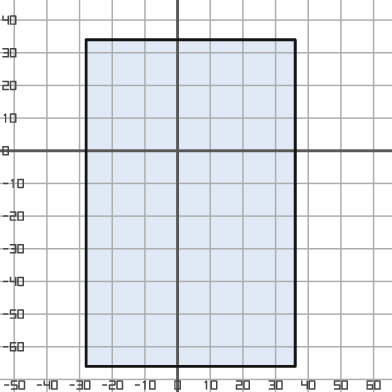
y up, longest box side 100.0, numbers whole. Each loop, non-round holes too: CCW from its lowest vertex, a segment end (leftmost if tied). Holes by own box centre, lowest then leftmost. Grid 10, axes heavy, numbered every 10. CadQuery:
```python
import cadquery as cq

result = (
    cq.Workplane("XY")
    .moveTo(-28.0, -66.0)
    .lineTo(36.0, -66.0)
    .lineTo(36.0, 34.0)
    .lineTo(-28.0, 34.0)
    .close()
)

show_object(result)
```